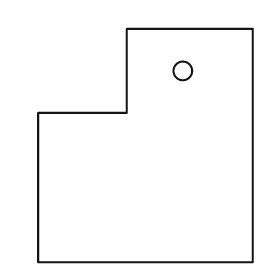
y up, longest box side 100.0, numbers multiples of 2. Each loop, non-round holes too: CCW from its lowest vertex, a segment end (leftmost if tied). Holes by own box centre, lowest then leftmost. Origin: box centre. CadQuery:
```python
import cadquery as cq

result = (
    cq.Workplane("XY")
    .moveTo(-46.0, -50.0)
    .lineTo(46.0, -50.0)
    .lineTo(46.0, 50.0)
    .lineTo(-8.0, 50.0)
    .lineTo(-8.0, 14.0)
    .lineTo(-46.0, 14.0)
    .close()
    .moveTo(16.0, 32.0)
    .circle(4.0)
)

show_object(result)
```